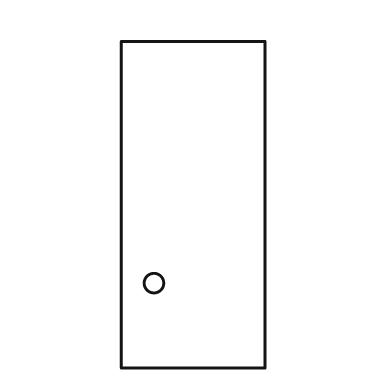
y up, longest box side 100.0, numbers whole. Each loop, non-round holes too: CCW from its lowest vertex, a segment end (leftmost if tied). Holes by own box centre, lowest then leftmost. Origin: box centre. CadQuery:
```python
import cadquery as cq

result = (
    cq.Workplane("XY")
    .moveTo(-22.0, -50.0)
    .lineTo(22.0, -50.0)
    .lineTo(22.0, 50.0)
    .lineTo(-22.0, 50.0)
    .close()
    .moveTo(-12.0, -24.0)
    .circle(3.0)
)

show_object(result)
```